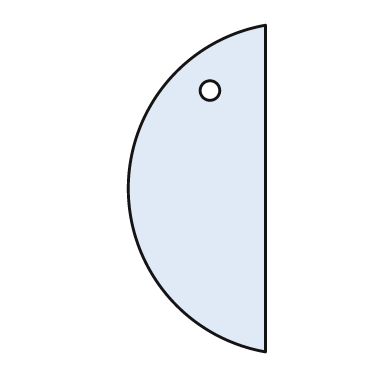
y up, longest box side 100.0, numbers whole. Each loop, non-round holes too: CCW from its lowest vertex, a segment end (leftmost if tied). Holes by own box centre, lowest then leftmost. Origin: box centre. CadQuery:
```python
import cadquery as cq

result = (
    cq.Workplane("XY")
    .moveTo(21.0, -50.0)
    .lineTo(21.0, 50.0)
    .threePointArc((-21.0, 0.0), (21.0, -50.0))
    .close()
    .moveTo(4.0, 30.0)
    .circle(3.0)
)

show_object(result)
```